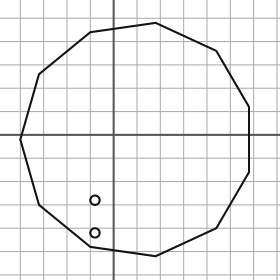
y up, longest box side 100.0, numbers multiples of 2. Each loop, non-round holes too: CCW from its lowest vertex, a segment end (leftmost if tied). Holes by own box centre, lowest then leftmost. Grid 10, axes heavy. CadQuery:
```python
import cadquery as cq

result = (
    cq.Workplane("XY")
    .moveTo(18.0, -52.0)
    .lineTo(44.0, -40.0)
    .lineTo(58.0, -16.0)
    .lineTo(58.0, 12.0)
    .lineTo(44.0, 36.0)
    .lineTo(18.0, 48.0)
    .lineTo(-10.0, 44.0)
    .lineTo(-32.0, 26.0)
    .lineTo(-40.0, -2.0)
    .lineTo(-32.0, -30.0)
    .lineTo(-10.0, -48.0)
    .close()
    .moveTo(-8.0, -42.0)
    .circle(2.0)
    .moveTo(-8.0, -28.0)
    .circle(2.0)
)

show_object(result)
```